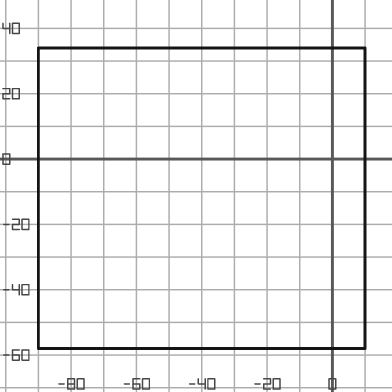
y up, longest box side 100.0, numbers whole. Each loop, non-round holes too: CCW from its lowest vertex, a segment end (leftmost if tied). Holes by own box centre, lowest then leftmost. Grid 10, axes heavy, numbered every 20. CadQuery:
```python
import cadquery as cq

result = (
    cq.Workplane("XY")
    .moveTo(-90.0, -58.0)
    .lineTo(10.0, -58.0)
    .lineTo(10.0, 34.0)
    .lineTo(-90.0, 34.0)
    .close()
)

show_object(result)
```